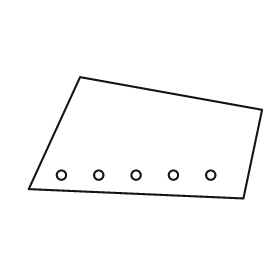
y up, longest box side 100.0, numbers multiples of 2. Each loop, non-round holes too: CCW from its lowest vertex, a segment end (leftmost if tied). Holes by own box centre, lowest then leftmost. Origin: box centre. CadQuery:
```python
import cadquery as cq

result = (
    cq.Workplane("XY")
    .moveTo(42.0, -26.0)
    .lineTo(50.0, 12.0)
    .lineTo(-28.0, 26.0)
    .lineTo(-50.0, -22.0)
    .close()
    .moveTo(-36.0, -16.0)
    .circle(2.0)
    .moveTo(-20.0, -16.0)
    .circle(2.0)
    .moveTo(-4.0, -16.0)
    .circle(2.0)
    .moveTo(12.0, -16.0)
    .circle(2.0)
    .moveTo(28.0, -16.0)
    .circle(2.0)
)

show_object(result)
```